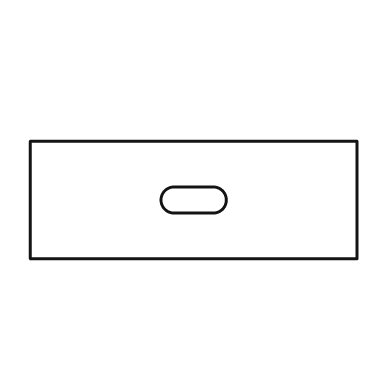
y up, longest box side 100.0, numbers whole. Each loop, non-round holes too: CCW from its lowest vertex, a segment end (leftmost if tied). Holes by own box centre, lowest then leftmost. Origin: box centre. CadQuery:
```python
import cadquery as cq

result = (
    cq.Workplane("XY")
    .moveTo(-50.0, -18.0)
    .lineTo(50.0, -18.0)
    .lineTo(50.0, 18.0)
    .lineTo(-50.0, 18.0)
    .close()
    .moveTo(-6.0, -4.0)
    .lineTo(6.0, -4.0)
    .threePointArc((10.0, 0.0), (6.0, 4.0))
    .lineTo(-6.0, 4.0)
    .threePointArc((-10.0, 0.0), (-6.0, -4.0))
    .close()
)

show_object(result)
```